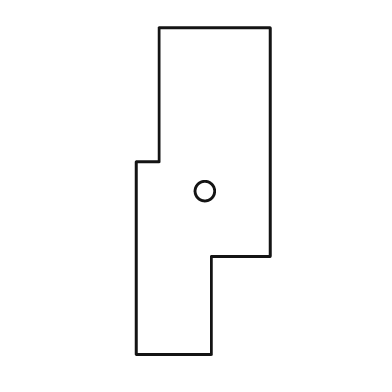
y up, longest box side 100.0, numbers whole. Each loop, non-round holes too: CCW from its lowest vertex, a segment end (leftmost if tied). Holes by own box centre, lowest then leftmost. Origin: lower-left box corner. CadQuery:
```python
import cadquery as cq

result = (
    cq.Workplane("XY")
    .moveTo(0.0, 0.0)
    .lineTo(23.0, 0.0)
    .lineTo(23.0, 30.0)
    .lineTo(41.0, 30.0)
    .lineTo(41.0, 100.0)
    .lineTo(7.0, 100.0)
    .lineTo(7.0, 59.0)
    .lineTo(0.0, 59.0)
    .close()
    .moveTo(21.0, 50.0)
    .circle(3.0)
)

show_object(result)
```